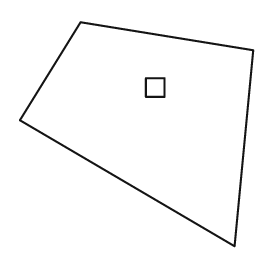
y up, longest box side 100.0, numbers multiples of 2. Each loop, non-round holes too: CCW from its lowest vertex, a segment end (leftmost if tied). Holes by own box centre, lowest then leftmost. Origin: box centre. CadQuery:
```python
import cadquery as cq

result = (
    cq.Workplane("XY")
    .moveTo(42.0, -48.0)
    .lineTo(50.0, 36.0)
    .lineTo(-24.0, 48.0)
    .lineTo(-50.0, 6.0)
    .close()
    .moveTo(4.0, 16.0)
    .lineTo(12.0, 16.0)
    .lineTo(12.0, 24.0)
    .lineTo(4.0, 24.0)
    .close()
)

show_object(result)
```